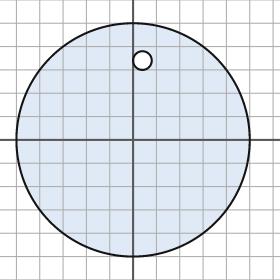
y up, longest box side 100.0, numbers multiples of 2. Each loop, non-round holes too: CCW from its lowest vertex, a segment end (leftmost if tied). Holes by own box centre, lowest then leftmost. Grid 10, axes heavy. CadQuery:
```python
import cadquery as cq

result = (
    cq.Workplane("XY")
    .moveTo(0.0, 0.0)
    .circle(50.0)
    .moveTo(4.0, 34.0)
    .circle(4.0)
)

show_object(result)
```